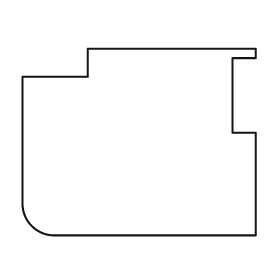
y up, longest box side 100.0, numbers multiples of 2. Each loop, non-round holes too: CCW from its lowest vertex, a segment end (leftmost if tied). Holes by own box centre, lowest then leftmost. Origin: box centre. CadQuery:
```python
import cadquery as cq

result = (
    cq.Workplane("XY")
    .moveTo(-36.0, -40.0)
    .lineTo(50.0, -40.0)
    .lineTo(50.0, 4.0)
    .lineTo(40.0, 4.0)
    .lineTo(40.0, 36.0)
    .lineTo(50.0, 36.0)
    .lineTo(50.0, 40.0)
    .lineTo(-22.0, 40.0)
    .lineTo(-22.0, 28.0)
    .lineTo(-50.0, 28.0)
    .lineTo(-50.0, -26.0)
    .threePointArc((-46.0, -36.0), (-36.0, -40.0))
    .close()
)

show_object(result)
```